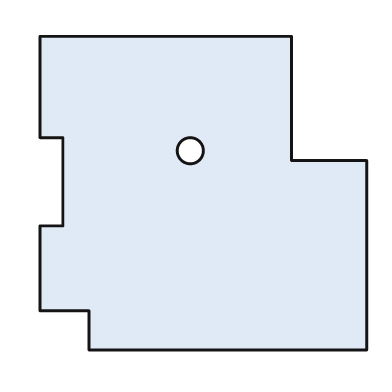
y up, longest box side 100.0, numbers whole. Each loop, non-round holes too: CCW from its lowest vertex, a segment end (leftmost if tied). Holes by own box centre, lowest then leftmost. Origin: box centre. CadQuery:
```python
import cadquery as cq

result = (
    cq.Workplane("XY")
    .moveTo(-35.0, -48.0)
    .lineTo(50.0, -48.0)
    .lineTo(50.0, 10.0)
    .lineTo(27.0, 10.0)
    .lineTo(27.0, 48.0)
    .lineTo(-50.0, 48.0)
    .lineTo(-50.0, 17.0)
    .lineTo(-43.0, 17.0)
    .lineTo(-43.0, -10.0)
    .lineTo(-50.0, -10.0)
    .lineTo(-50.0, -36.0)
    .lineTo(-35.0, -36.0)
    .close()
    .moveTo(-4.0, 13.0)
    .circle(4.0)
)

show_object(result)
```